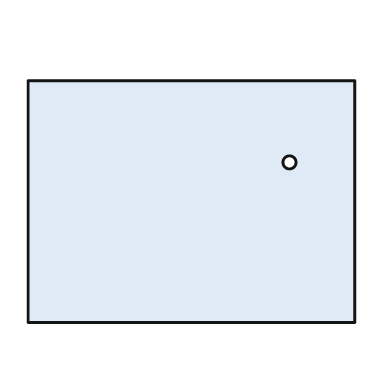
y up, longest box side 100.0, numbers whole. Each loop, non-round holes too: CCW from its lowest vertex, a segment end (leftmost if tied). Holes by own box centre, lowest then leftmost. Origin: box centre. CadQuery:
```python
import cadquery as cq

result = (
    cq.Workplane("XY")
    .moveTo(-50.0, -37.0)
    .lineTo(50.0, -37.0)
    .lineTo(50.0, 37.0)
    .lineTo(-50.0, 37.0)
    .close()
    .moveTo(30.0, 12.0)
    .circle(2.0)
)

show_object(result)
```